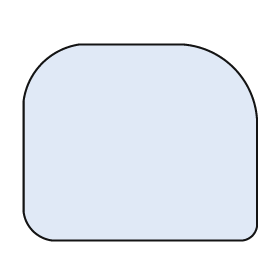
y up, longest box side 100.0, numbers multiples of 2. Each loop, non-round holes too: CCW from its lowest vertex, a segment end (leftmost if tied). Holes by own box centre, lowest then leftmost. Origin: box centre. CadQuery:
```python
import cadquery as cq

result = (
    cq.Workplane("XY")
    .moveTo(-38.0, -42.0)
    .lineTo(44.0, -42.0)
    .threePointArc((48.0, -40.0), (50.0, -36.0))
    .lineTo(50.0, 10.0)
    .threePointArc((40.0, 32.0), (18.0, 42.0))
    .lineTo(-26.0, 42.0)
    .threePointArc((-42.0, 34.0), (-50.0, 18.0))
    .lineTo(-50.0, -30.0)
    .threePointArc((-46.0, -38.0), (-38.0, -42.0))
    .close()
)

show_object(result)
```